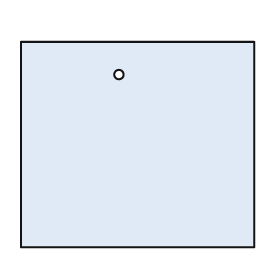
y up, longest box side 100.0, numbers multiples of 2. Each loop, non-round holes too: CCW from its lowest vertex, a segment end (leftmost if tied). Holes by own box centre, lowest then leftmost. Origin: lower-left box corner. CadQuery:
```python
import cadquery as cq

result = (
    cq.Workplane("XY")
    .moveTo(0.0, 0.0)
    .lineTo(100.0, 0.0)
    .lineTo(100.0, 88.0)
    .lineTo(0.0, 88.0)
    .close()
    .moveTo(42.0, 74.0)
    .circle(2.0)
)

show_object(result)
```